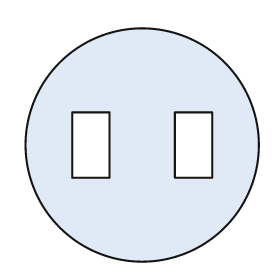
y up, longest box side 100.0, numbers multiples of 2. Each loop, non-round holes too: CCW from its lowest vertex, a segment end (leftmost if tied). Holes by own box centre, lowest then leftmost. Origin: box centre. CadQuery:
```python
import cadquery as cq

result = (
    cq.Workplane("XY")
    .moveTo(0.0, 0.0)
    .circle(50.0)
    .moveTo(-30.0, -14.0)
    .lineTo(-14.0, -14.0)
    .lineTo(-14.0, 14.0)
    .lineTo(-30.0, 14.0)
    .close()
    .moveTo(14.0, -14.0)
    .lineTo(30.0, -14.0)
    .lineTo(30.0, 14.0)
    .lineTo(14.0, 14.0)
    .close()
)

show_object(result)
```